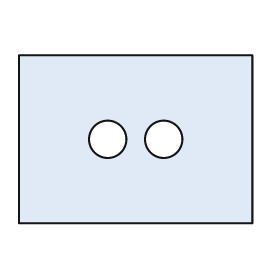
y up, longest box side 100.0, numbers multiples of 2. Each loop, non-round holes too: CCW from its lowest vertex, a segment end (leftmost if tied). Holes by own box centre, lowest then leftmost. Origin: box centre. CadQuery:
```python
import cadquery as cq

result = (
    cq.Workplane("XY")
    .moveTo(-50.0, -36.0)
    .lineTo(50.0, -36.0)
    .lineTo(50.0, 36.0)
    .lineTo(-50.0, 36.0)
    .close()
    .moveTo(-12.0, 0.0)
    .circle(8.0)
    .moveTo(12.0, 0.0)
    .circle(8.0)
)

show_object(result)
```